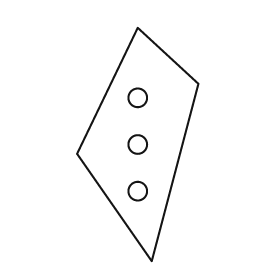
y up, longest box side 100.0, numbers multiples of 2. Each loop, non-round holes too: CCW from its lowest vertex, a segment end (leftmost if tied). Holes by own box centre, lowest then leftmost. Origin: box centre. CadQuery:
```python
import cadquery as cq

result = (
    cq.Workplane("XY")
    .moveTo(6.0, -50.0)
    .lineTo(26.0, 26.0)
    .lineTo(0.0, 50.0)
    .lineTo(-26.0, -4.0)
    .close()
    .moveTo(0.0, -20.0)
    .circle(4.0)
    .moveTo(0.0, 0.0)
    .circle(4.0)
    .moveTo(0.0, 20.0)
    .circle(4.0)
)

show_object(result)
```